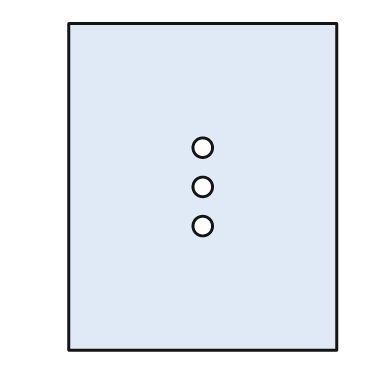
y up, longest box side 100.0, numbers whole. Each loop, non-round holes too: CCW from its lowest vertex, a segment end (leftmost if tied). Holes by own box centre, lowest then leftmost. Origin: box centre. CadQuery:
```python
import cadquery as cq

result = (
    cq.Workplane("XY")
    .moveTo(-41.0, -50.0)
    .lineTo(41.0, -50.0)
    .lineTo(41.0, 50.0)
    .lineTo(-41.0, 50.0)
    .close()
    .moveTo(0.0, -12.0)
    .circle(3.0)
    .moveTo(0.0, 0.0)
    .circle(3.0)
    .moveTo(0.0, 12.0)
    .circle(3.0)
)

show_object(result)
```